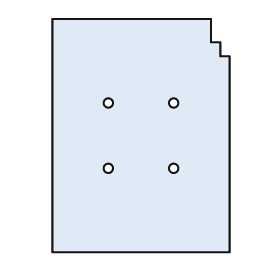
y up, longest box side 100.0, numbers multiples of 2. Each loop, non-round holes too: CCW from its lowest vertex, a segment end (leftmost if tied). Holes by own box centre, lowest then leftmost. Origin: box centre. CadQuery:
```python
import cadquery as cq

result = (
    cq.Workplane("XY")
    .moveTo(-38.0, -50.0)
    .lineTo(38.0, -50.0)
    .lineTo(38.0, 34.0)
    .lineTo(34.0, 34.0)
    .lineTo(34.0, 40.0)
    .lineTo(30.0, 40.0)
    .lineTo(30.0, 50.0)
    .lineTo(-38.0, 50.0)
    .close()
    .moveTo(-14.0, -14.0)
    .circle(2.0)
    .moveTo(14.0, -14.0)
    .circle(2.0)
    .moveTo(-14.0, 14.0)
    .circle(2.0)
    .moveTo(14.0, 14.0)
    .circle(2.0)
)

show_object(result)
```